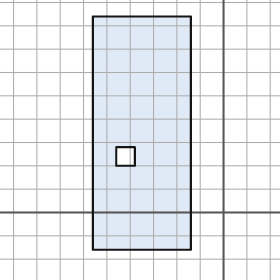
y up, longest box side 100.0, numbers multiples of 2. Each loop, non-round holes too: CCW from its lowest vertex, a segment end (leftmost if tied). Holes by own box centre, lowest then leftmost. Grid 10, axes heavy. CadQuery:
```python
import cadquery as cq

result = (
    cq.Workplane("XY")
    .moveTo(-56.0, -16.0)
    .lineTo(-14.0, -16.0)
    .lineTo(-14.0, 84.0)
    .lineTo(-56.0, 84.0)
    .close()
    .moveTo(-46.0, 20.0)
    .lineTo(-38.0, 20.0)
    .lineTo(-38.0, 28.0)
    .lineTo(-46.0, 28.0)
    .close()
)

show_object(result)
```